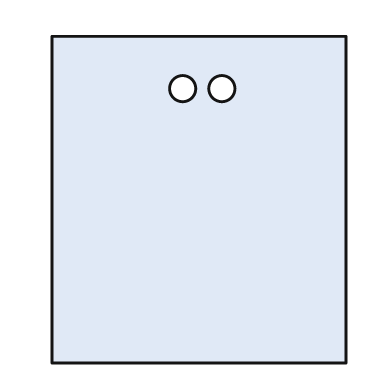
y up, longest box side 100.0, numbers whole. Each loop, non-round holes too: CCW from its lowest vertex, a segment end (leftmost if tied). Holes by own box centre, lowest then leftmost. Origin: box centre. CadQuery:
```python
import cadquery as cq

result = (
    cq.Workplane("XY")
    .moveTo(-45.0, -50.0)
    .lineTo(45.0, -50.0)
    .lineTo(45.0, 50.0)
    .lineTo(-45.0, 50.0)
    .close()
    .moveTo(-5.0, 34.0)
    .circle(4.0)
    .moveTo(7.0, 34.0)
    .circle(4.0)
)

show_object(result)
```